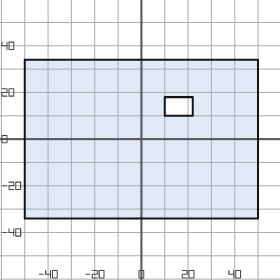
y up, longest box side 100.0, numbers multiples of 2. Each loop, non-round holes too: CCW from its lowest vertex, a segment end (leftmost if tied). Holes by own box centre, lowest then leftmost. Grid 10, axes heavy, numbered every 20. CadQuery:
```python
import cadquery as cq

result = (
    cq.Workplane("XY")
    .moveTo(-50.0, -34.0)
    .lineTo(50.0, -34.0)
    .lineTo(50.0, 34.0)
    .lineTo(-50.0, 34.0)
    .close()
    .moveTo(10.0, 10.0)
    .lineTo(22.0, 10.0)
    .lineTo(22.0, 18.0)
    .lineTo(10.0, 18.0)
    .close()
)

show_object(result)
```